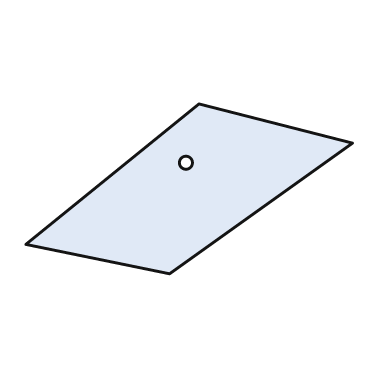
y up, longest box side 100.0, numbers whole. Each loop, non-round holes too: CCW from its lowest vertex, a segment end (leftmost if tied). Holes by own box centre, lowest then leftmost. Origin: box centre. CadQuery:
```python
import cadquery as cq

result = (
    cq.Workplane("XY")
    .moveTo(-6.0, -26.0)
    .lineTo(50.0, 14.0)
    .lineTo(3.0, 26.0)
    .lineTo(-50.0, -17.0)
    .close()
    .moveTo(-1.0, 8.0)
    .circle(2.0)
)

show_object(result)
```